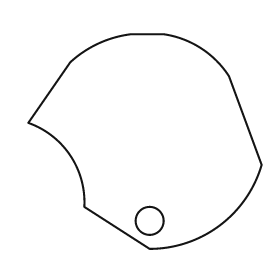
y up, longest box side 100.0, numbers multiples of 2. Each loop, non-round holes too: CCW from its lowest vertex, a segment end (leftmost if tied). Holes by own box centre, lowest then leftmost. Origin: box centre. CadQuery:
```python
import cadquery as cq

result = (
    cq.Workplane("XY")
    .moveTo(2.0, -46.0)
    .threePointArc((32.0, -36.0), (50.0, -10.0))
    .lineTo(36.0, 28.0)
    .threePointArc((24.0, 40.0), (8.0, 46.0))
    .lineTo(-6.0, 46.0)
    .threePointArc((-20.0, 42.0), (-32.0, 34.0))
    .lineTo(-50.0, 8.0)
    .threePointArc((-32.0, -6.0), (-26.0, -28.0))
    .close()
    .moveTo(2.0, -34.0)
    .circle(6.0)
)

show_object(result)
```